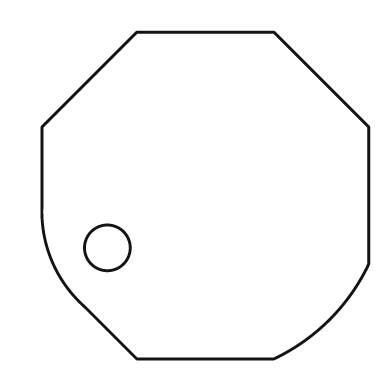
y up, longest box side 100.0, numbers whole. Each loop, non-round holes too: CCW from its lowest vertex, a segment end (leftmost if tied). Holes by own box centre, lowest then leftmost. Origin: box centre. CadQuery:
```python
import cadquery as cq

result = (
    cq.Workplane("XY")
    .moveTo(-21.0, -50.0)
    .lineTo(21.0, -50.0)
    .threePointArc((38.0, -38.0), (50.0, -21.0))
    .lineTo(50.0, 21.0)
    .lineTo(21.0, 50.0)
    .lineTo(-21.0, 50.0)
    .lineTo(-50.0, 21.0)
    .lineTo(-50.0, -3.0)
    .threePointArc((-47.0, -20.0), (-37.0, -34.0))
    .close()
    .moveTo(-30.0, -16.0)
    .circle(7.0)
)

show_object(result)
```